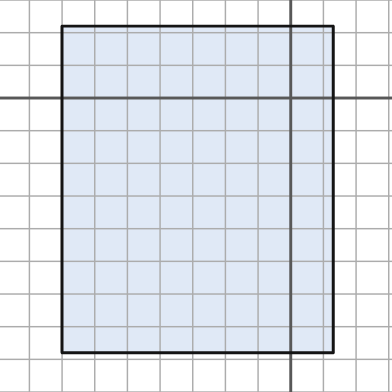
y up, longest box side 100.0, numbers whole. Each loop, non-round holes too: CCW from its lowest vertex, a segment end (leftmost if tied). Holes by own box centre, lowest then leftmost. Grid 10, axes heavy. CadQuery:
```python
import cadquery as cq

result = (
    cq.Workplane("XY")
    .moveTo(-70.0, -78.0)
    .lineTo(13.0, -78.0)
    .lineTo(13.0, 22.0)
    .lineTo(-70.0, 22.0)
    .close()
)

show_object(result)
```